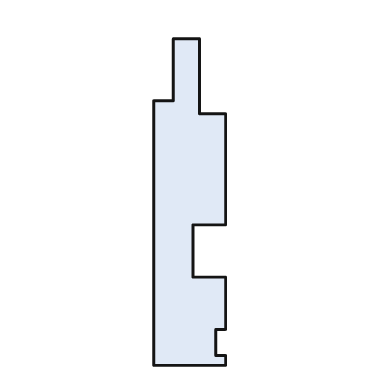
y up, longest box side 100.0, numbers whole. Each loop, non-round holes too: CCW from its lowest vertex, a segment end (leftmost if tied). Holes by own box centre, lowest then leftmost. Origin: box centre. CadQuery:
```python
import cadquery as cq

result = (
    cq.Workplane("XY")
    .moveTo(-11.0, -50.0)
    .lineTo(11.0, -50.0)
    .lineTo(11.0, -47.0)
    .lineTo(8.0, -47.0)
    .lineTo(8.0, -39.0)
    .lineTo(11.0, -39.0)
    .lineTo(11.0, -23.0)
    .lineTo(1.0, -23.0)
    .lineTo(1.0, -7.0)
    .lineTo(11.0, -7.0)
    .lineTo(11.0, 27.0)
    .lineTo(3.0, 27.0)
    .lineTo(3.0, 50.0)
    .lineTo(-5.0, 50.0)
    .lineTo(-5.0, 31.0)
    .lineTo(-11.0, 31.0)
    .close()
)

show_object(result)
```